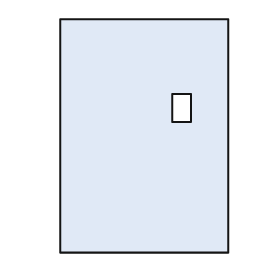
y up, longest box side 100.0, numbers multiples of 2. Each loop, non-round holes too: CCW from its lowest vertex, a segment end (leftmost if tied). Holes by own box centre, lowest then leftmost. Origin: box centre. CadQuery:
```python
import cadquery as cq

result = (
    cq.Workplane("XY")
    .moveTo(-36.0, -50.0)
    .lineTo(36.0, -50.0)
    .lineTo(36.0, 50.0)
    .lineTo(-36.0, 50.0)
    .close()
    .moveTo(12.0, 6.0)
    .lineTo(20.0, 6.0)
    .lineTo(20.0, 18.0)
    .lineTo(12.0, 18.0)
    .close()
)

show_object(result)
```